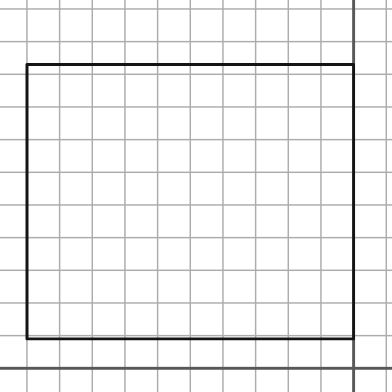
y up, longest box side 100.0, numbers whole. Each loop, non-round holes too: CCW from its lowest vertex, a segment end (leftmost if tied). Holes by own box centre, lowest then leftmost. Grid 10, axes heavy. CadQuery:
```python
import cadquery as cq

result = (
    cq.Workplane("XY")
    .moveTo(-100.0, 9.0)
    .lineTo(0.0, 9.0)
    .lineTo(0.0, 93.0)
    .lineTo(-100.0, 93.0)
    .close()
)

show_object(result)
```